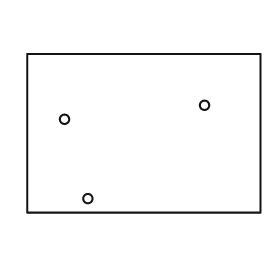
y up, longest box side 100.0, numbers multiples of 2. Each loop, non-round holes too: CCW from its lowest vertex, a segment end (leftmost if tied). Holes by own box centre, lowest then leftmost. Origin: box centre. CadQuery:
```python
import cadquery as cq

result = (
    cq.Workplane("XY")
    .moveTo(-50.0, -34.0)
    .lineTo(50.0, -34.0)
    .lineTo(50.0, 34.0)
    .lineTo(-50.0, 34.0)
    .close()
    .moveTo(-24.0, -28.0)
    .circle(2.0)
    .moveTo(-34.0, 6.0)
    .circle(2.0)
    .moveTo(26.0, 12.0)
    .circle(2.0)
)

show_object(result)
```